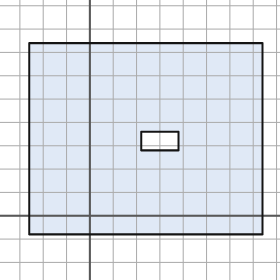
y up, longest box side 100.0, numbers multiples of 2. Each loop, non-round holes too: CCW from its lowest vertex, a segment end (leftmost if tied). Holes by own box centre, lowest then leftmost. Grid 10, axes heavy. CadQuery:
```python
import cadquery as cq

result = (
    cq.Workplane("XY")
    .moveTo(-26.0, -8.0)
    .lineTo(74.0, -8.0)
    .lineTo(74.0, 74.0)
    .lineTo(-26.0, 74.0)
    .close()
    .moveTo(22.0, 28.0)
    .lineTo(38.0, 28.0)
    .lineTo(38.0, 36.0)
    .lineTo(22.0, 36.0)
    .close()
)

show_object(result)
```